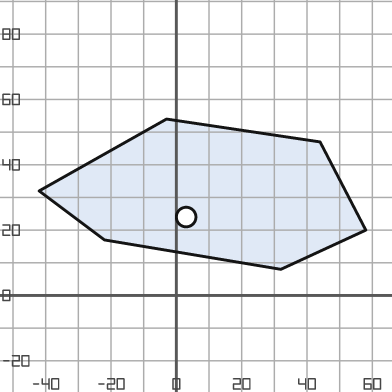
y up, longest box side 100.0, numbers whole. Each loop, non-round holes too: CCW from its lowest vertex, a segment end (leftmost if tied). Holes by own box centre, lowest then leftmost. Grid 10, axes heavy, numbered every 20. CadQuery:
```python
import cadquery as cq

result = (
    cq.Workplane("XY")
    .moveTo(32.0, 8.0)
    .lineTo(58.0, 20.0)
    .lineTo(44.0, 47.0)
    .lineTo(-3.0, 54.0)
    .lineTo(-42.0, 32.0)
    .lineTo(-22.0, 17.0)
    .close()
    .moveTo(3.0, 24.0)
    .circle(3.0)
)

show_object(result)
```